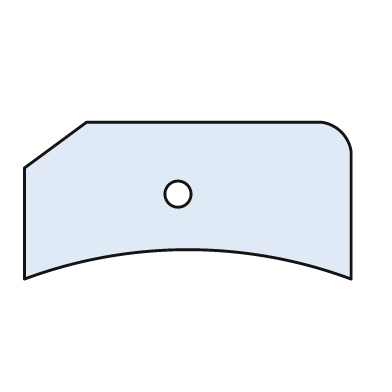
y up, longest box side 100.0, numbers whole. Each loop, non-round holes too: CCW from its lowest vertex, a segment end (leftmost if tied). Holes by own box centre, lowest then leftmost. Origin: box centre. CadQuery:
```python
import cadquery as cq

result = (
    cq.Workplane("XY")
    .moveTo(-50.0, -24.0)
    .threePointArc((0.0, -15.0), (50.0, -24.0))
    .lineTo(50.0, 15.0)
    .threePointArc((47.0, 21.0), (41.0, 24.0))
    .lineTo(-31.0, 24.0)
    .lineTo(-50.0, 10.0)
    .close()
    .moveTo(-3.0, 2.0)
    .circle(4.0)
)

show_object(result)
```